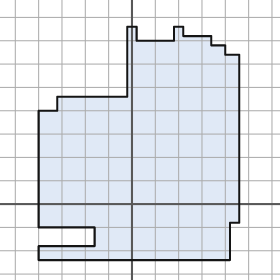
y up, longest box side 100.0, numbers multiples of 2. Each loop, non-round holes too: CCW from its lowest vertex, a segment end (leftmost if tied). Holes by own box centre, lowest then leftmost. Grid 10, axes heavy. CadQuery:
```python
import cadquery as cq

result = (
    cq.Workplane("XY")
    .moveTo(-40.0, -24.0)
    .lineTo(42.0, -24.0)
    .lineTo(42.0, -8.0)
    .lineTo(46.0, -8.0)
    .lineTo(46.0, 64.0)
    .lineTo(40.0, 64.0)
    .lineTo(40.0, 68.0)
    .lineTo(34.0, 68.0)
    .lineTo(34.0, 72.0)
    .lineTo(22.0, 72.0)
    .lineTo(22.0, 76.0)
    .lineTo(18.0, 76.0)
    .lineTo(18.0, 70.0)
    .lineTo(2.0, 70.0)
    .lineTo(2.0, 76.0)
    .lineTo(-2.0, 76.0)
    .lineTo(-2.0, 46.0)
    .lineTo(-32.0, 46.0)
    .lineTo(-32.0, 40.0)
    .lineTo(-40.0, 40.0)
    .lineTo(-40.0, -10.0)
    .lineTo(-16.0, -10.0)
    .lineTo(-16.0, -18.0)
    .lineTo(-40.0, -18.0)
    .close()
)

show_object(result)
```